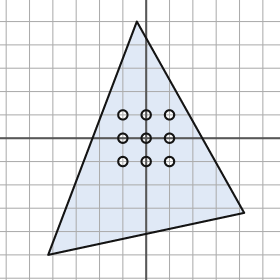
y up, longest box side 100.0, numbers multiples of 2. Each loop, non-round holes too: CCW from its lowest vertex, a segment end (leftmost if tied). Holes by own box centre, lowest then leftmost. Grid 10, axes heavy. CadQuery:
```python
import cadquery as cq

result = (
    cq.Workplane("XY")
    .moveTo(-42.0, -50.0)
    .lineTo(42.0, -32.0)
    .lineTo(-4.0, 50.0)
    .close()
    .moveTo(-10.0, -10.0)
    .circle(2.0)
    .moveTo(0.0, -10.0)
    .circle(2.0)
    .moveTo(10.0, -10.0)
    .circle(2.0)
    .moveTo(-10.0, 0.0)
    .circle(2.0)
    .moveTo(0.0, 0.0)
    .circle(2.0)
    .moveTo(10.0, 0.0)
    .circle(2.0)
    .moveTo(-10.0, 10.0)
    .circle(2.0)
    .moveTo(0.0, 10.0)
    .circle(2.0)
    .moveTo(10.0, 10.0)
    .circle(2.0)
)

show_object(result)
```